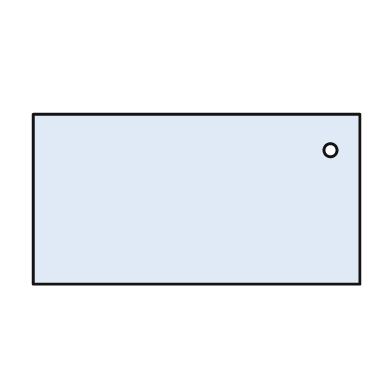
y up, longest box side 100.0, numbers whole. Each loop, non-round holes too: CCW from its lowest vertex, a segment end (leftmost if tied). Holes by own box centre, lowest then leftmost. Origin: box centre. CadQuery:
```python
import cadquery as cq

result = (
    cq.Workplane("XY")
    .moveTo(-50.0, -26.0)
    .lineTo(50.0, -26.0)
    .lineTo(50.0, 26.0)
    .lineTo(-50.0, 26.0)
    .close()
    .moveTo(41.0, 15.0)
    .circle(2.0)
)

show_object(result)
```